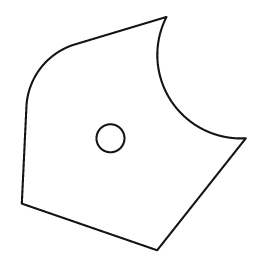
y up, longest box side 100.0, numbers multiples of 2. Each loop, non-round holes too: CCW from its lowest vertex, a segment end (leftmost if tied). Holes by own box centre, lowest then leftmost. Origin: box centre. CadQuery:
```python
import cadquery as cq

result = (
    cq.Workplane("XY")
    .moveTo(10.0, -50.0)
    .lineTo(48.0, -2.0)
    .threePointArc((16.0, 14.0), (14.0, 50.0))
    .lineTo(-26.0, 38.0)
    .threePointArc((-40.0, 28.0), (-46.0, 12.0))
    .lineTo(-48.0, -30.0)
    .close()
    .moveTo(-10.0, -2.0)
    .circle(6.0)
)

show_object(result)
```